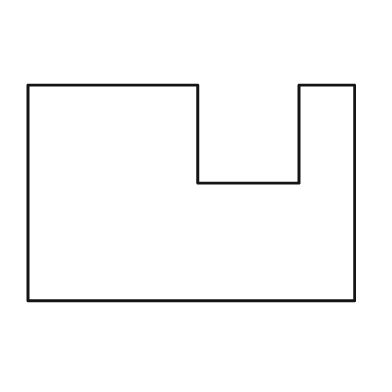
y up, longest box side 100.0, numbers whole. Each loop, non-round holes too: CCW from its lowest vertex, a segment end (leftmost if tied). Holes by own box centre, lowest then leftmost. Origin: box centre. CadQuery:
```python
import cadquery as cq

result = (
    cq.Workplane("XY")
    .moveTo(-50.0, -33.0)
    .lineTo(50.0, -33.0)
    .lineTo(50.0, 33.0)
    .lineTo(33.0, 33.0)
    .lineTo(33.0, 3.0)
    .lineTo(2.0, 3.0)
    .lineTo(2.0, 33.0)
    .lineTo(-50.0, 33.0)
    .close()
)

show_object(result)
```